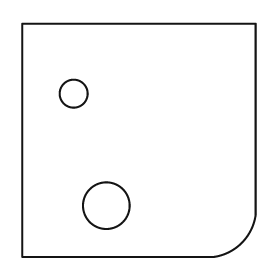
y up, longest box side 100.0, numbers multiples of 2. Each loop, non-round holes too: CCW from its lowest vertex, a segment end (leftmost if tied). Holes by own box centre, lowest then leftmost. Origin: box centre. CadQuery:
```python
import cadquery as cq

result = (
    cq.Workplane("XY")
    .moveTo(-50.0, -50.0)
    .lineTo(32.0, -50.0)
    .threePointArc((44.0, -44.0), (50.0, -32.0))
    .lineTo(50.0, 50.0)
    .lineTo(-50.0, 50.0)
    .close()
    .moveTo(-14.0, -28.0)
    .circle(10.0)
    .moveTo(-28.0, 20.0)
    .circle(6.0)
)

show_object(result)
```